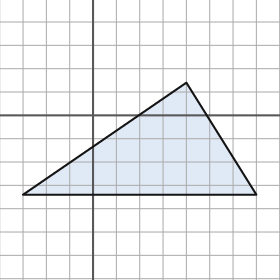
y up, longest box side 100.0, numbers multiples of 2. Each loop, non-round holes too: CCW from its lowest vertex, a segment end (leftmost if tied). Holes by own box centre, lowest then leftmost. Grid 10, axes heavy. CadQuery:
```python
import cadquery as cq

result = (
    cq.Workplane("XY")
    .moveTo(-30.0, -34.0)
    .lineTo(70.0, -34.0)
    .lineTo(40.0, 14.0)
    .close()
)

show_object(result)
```